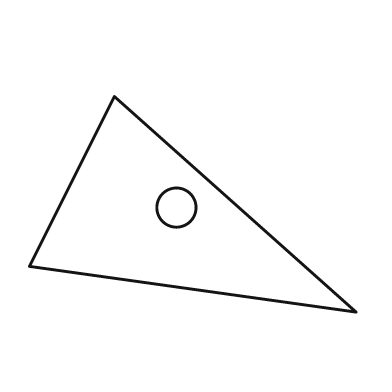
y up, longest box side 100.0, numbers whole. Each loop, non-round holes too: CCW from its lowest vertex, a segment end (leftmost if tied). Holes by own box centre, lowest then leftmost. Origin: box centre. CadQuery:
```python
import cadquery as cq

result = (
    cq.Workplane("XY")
    .moveTo(50.0, -33.0)
    .lineTo(-24.0, 33.0)
    .lineTo(-50.0, -19.0)
    .close()
    .moveTo(-5.0, -1.0)
    .circle(6.0)
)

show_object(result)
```